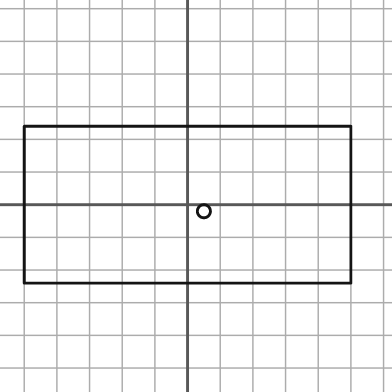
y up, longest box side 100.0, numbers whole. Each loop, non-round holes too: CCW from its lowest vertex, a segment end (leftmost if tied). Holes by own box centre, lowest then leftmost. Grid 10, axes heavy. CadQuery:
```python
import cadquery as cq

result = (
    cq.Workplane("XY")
    .moveTo(-50.0, -24.0)
    .lineTo(50.0, -24.0)
    .lineTo(50.0, 24.0)
    .lineTo(-50.0, 24.0)
    .close()
    .moveTo(5.0, -2.0)
    .circle(2.0)
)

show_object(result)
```